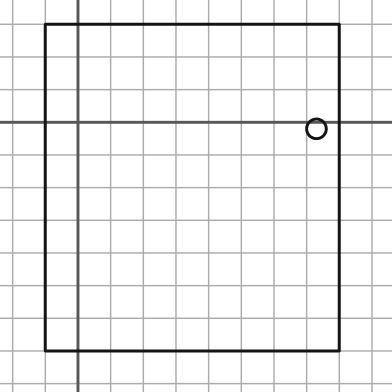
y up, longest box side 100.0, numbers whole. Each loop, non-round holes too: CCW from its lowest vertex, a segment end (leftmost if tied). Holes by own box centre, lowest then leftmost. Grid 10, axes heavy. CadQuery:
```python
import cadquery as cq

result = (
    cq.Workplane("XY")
    .moveTo(-10.0, -70.0)
    .lineTo(80.0, -70.0)
    .lineTo(80.0, 30.0)
    .lineTo(-10.0, 30.0)
    .close()
    .moveTo(73.0, -2.0)
    .circle(3.0)
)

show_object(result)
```